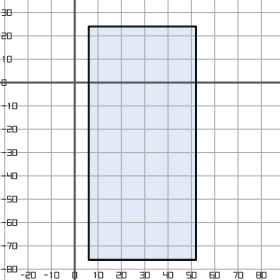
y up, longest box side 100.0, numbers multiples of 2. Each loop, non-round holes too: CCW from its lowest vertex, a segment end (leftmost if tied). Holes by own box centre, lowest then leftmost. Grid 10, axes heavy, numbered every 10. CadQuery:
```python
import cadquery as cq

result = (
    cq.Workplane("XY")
    .moveTo(6.0, -76.0)
    .lineTo(52.0, -76.0)
    .lineTo(52.0, 24.0)
    .lineTo(6.0, 24.0)
    .close()
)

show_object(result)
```